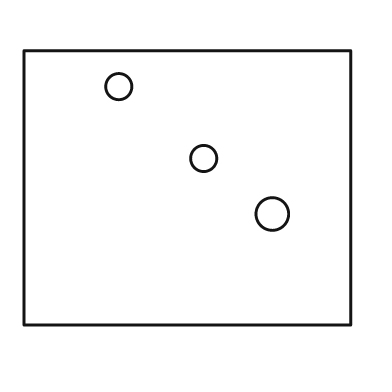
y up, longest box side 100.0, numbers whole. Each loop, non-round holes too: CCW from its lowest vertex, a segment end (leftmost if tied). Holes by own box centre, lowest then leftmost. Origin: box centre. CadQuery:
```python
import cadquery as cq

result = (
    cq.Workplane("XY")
    .moveTo(-50.0, -42.0)
    .lineTo(50.0, -42.0)
    .lineTo(50.0, 42.0)
    .lineTo(-50.0, 42.0)
    .close()
    .moveTo(26.0, -8.0)
    .circle(5.0)
    .moveTo(5.0, 9.0)
    .circle(4.0)
    .moveTo(-21.0, 31.0)
    .circle(4.0)
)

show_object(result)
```